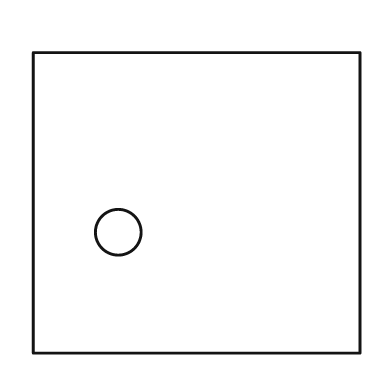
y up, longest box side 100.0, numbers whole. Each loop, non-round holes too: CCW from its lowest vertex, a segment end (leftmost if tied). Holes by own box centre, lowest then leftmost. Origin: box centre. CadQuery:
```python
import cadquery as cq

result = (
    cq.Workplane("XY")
    .moveTo(-50.0, -46.0)
    .lineTo(50.0, -46.0)
    .lineTo(50.0, 46.0)
    .lineTo(-50.0, 46.0)
    .close()
    .moveTo(-24.0, -9.0)
    .circle(7.0)
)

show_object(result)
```